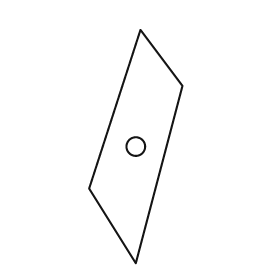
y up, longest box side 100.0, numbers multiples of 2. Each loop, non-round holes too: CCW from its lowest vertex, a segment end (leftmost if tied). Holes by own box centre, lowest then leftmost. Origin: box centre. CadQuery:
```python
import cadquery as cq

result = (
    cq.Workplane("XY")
    .moveTo(0.0, -50.0)
    .lineTo(20.0, 26.0)
    .lineTo(2.0, 50.0)
    .lineTo(-20.0, -18.0)
    .close()
    .moveTo(0.0, 0.0)
    .circle(4.0)
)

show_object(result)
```